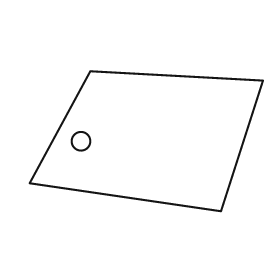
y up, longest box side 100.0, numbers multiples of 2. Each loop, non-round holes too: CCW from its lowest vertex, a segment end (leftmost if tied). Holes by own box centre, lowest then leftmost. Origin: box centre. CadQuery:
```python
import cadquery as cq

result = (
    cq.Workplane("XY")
    .moveTo(32.0, -30.0)
    .lineTo(50.0, 26.0)
    .lineTo(-24.0, 30.0)
    .lineTo(-50.0, -18.0)
    .close()
    .moveTo(-28.0, 0.0)
    .circle(4.0)
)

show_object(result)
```